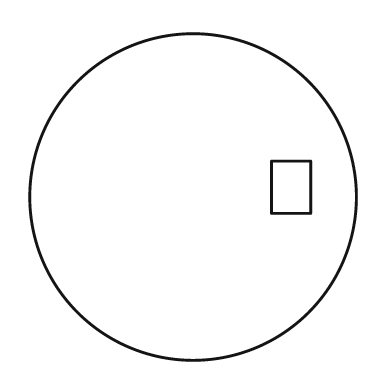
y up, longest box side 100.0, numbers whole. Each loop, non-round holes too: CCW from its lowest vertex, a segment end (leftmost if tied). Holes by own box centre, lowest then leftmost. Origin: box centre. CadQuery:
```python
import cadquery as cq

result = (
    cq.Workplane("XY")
    .moveTo(0.0, 0.0)
    .circle(50.0)
    .moveTo(24.0, -5.0)
    .lineTo(36.0, -5.0)
    .lineTo(36.0, 11.0)
    .lineTo(24.0, 11.0)
    .close()
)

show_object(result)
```